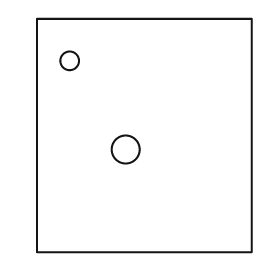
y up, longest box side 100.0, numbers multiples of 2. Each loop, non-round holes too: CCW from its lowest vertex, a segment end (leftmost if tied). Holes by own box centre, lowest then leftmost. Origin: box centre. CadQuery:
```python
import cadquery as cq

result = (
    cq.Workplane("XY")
    .moveTo(-46.0, -50.0)
    .lineTo(46.0, -50.0)
    .lineTo(46.0, 50.0)
    .lineTo(-46.0, 50.0)
    .close()
    .moveTo(-8.0, -6.0)
    .circle(6.0)
    .moveTo(-32.0, 32.0)
    .circle(4.0)
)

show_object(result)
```